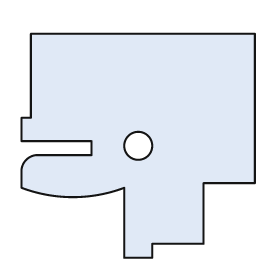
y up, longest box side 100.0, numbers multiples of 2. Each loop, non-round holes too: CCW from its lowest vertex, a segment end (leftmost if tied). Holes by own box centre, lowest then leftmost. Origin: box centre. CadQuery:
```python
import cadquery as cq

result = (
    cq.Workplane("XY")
    .moveTo(-6.0, -48.0)
    .lineTo(6.0, -48.0)
    .lineTo(6.0, -42.0)
    .lineTo(28.0, -42.0)
    .lineTo(28.0, -16.0)
    .lineTo(50.0, -16.0)
    .lineTo(50.0, 48.0)
    .lineTo(-46.0, 48.0)
    .lineTo(-46.0, 12.0)
    .lineTo(-50.0, 12.0)
    .lineTo(-50.0, 2.0)
    .lineTo(-20.0, 2.0)
    .lineTo(-20.0, -4.0)
    .lineTo(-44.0, -4.0)
    .threePointArc((-48.0, -6.0), (-50.0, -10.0))
    .lineTo(-50.0, -18.0)
    .threePointArc((-28.0, -22.0), (-6.0, -18.0))
    .close()
    .moveTo(0.0, 0.0)
    .circle(6.0)
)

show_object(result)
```